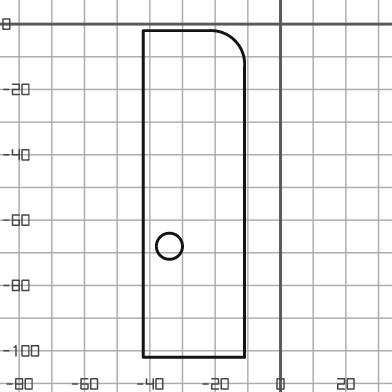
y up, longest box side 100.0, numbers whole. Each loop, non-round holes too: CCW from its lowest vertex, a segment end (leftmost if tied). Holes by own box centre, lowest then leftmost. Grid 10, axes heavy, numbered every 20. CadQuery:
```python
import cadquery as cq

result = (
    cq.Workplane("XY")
    .moveTo(-42.0, -102.0)
    .lineTo(-11.0, -102.0)
    .lineTo(-11.0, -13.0)
    .threePointArc((-14.0, -5.0), (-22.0, -2.0))
    .lineTo(-42.0, -2.0)
    .close()
    .moveTo(-34.0, -68.0)
    .circle(4.0)
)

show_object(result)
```